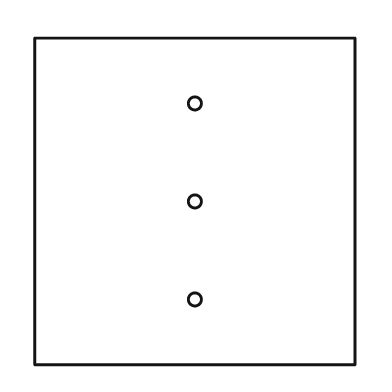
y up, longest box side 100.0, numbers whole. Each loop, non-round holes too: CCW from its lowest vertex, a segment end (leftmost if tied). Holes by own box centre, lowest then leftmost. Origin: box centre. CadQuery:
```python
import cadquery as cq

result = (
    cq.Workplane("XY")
    .moveTo(-49.0, -50.0)
    .lineTo(49.0, -50.0)
    .lineTo(49.0, 50.0)
    .lineTo(-49.0, 50.0)
    .close()
    .moveTo(0.0, -30.0)
    .circle(2.0)
    .moveTo(0.0, 0.0)
    .circle(2.0)
    .moveTo(0.0, 30.0)
    .circle(2.0)
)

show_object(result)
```